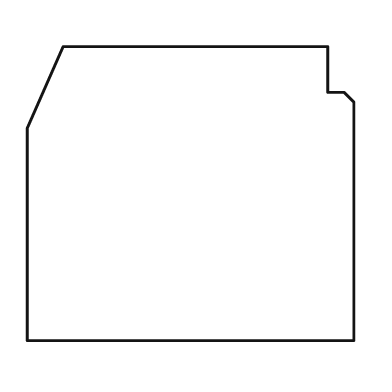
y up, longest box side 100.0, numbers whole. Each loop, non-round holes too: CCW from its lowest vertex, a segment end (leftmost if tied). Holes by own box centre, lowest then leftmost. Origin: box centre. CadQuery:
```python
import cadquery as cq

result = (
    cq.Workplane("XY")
    .moveTo(-50.0, -45.0)
    .lineTo(50.0, -45.0)
    .lineTo(50.0, 28.0)
    .lineTo(47.0, 31.0)
    .lineTo(42.0, 31.0)
    .lineTo(42.0, 45.0)
    .lineTo(-39.0, 45.0)
    .lineTo(-50.0, 20.0)
    .close()
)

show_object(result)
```